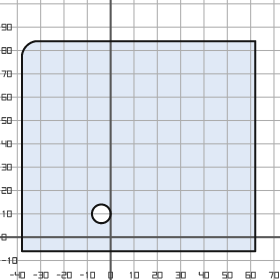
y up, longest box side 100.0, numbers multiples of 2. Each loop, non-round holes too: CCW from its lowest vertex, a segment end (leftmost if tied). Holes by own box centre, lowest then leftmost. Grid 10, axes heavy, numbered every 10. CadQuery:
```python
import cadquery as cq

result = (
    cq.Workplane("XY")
    .moveTo(-38.0, -6.0)
    .lineTo(62.0, -6.0)
    .lineTo(62.0, 84.0)
    .lineTo(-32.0, 84.0)
    .threePointArc((-36.0, 82.0), (-38.0, 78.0))
    .close()
    .moveTo(-4.0, 10.0)
    .circle(4.0)
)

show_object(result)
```